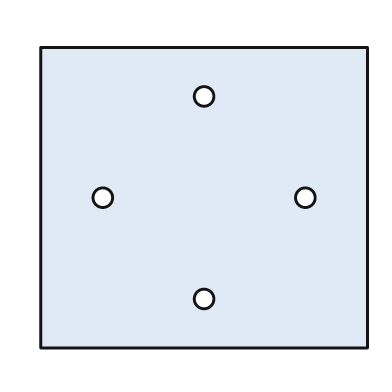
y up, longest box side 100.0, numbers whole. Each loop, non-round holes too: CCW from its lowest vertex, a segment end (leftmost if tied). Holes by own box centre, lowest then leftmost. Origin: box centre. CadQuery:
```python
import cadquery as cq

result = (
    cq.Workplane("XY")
    .moveTo(-50.0, -46.0)
    .lineTo(50.0, -46.0)
    .lineTo(50.0, 46.0)
    .lineTo(-50.0, 46.0)
    .close()
    .moveTo(0.0, -31.0)
    .circle(3.0)
    .moveTo(-31.0, 0.0)
    .circle(3.0)
    .moveTo(31.0, 0.0)
    .circle(3.0)
    .moveTo(0.0, 31.0)
    .circle(3.0)
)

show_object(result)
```